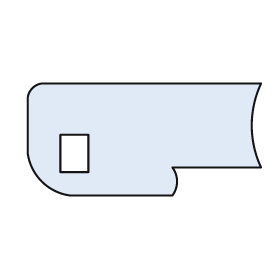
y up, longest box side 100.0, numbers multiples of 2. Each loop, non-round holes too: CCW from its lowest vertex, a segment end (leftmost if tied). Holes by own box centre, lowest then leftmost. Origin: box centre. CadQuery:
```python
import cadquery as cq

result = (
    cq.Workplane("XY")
    .moveTo(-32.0, -24.0)
    .lineTo(12.0, -24.0)
    .threePointArc((14.0, -18.0), (12.0, -12.0))
    .lineTo(50.0, -12.0)
    .threePointArc((46.0, 6.0), (50.0, 24.0))
    .lineTo(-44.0, 24.0)
    .threePointArc((-48.0, 22.0), (-50.0, 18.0))
    .lineTo(-50.0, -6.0)
    .threePointArc((-44.0, -18.0), (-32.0, -24.0))
    .close()
    .moveTo(-36.0, -14.0)
    .lineTo(-24.0, -14.0)
    .lineTo(-24.0, 2.0)
    .lineTo(-36.0, 2.0)
    .close()
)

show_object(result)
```